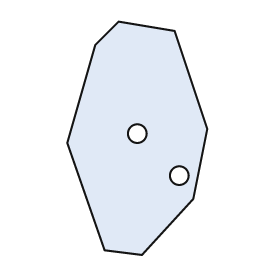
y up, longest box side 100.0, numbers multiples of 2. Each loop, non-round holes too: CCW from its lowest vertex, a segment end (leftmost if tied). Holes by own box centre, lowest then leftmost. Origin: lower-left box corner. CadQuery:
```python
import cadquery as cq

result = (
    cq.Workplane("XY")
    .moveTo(32.0, 0.0)
    .lineTo(54.0, 24.0)
    .lineTo(60.0, 54.0)
    .lineTo(46.0, 96.0)
    .lineTo(22.0, 100.0)
    .lineTo(12.0, 90.0)
    .lineTo(0.0, 48.0)
    .lineTo(16.0, 2.0)
    .close()
    .moveTo(48.0, 34.0)
    .circle(4.0)
    .moveTo(30.0, 52.0)
    .circle(4.0)
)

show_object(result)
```